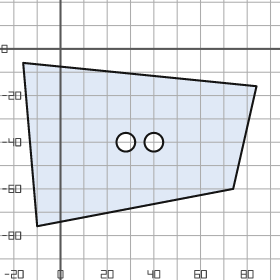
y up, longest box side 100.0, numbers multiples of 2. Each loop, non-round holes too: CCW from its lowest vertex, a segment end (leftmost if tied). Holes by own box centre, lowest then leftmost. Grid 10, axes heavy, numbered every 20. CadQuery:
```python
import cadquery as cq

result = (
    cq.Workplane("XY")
    .moveTo(-10.0, -76.0)
    .lineTo(74.0, -60.0)
    .lineTo(84.0, -16.0)
    .lineTo(-16.0, -6.0)
    .close()
    .moveTo(28.0, -40.0)
    .circle(4.0)
    .moveTo(40.0, -40.0)
    .circle(4.0)
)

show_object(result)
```